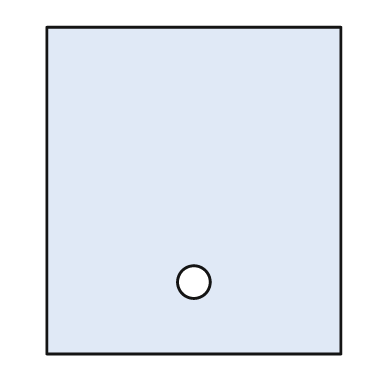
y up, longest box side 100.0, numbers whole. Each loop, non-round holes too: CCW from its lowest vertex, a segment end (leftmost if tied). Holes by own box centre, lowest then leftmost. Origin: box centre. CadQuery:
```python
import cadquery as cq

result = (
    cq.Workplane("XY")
    .moveTo(-45.0, -50.0)
    .lineTo(45.0, -50.0)
    .lineTo(45.0, 50.0)
    .lineTo(-45.0, 50.0)
    .close()
    .moveTo(0.0, -28.0)
    .circle(5.0)
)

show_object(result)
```